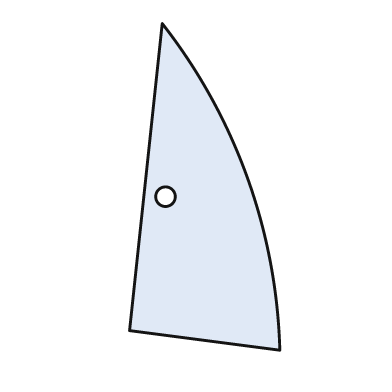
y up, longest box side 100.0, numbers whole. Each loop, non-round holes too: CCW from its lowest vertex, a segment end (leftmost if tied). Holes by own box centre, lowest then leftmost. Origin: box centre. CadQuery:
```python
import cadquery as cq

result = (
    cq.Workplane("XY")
    .moveTo(23.0, -50.0)
    .threePointArc((13.0, 3.0), (-13.0, 50.0))
    .lineTo(-23.0, -44.0)
    .close()
    .moveTo(-12.0, -3.0)
    .circle(3.0)
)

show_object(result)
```